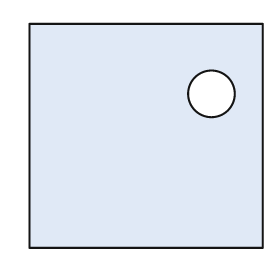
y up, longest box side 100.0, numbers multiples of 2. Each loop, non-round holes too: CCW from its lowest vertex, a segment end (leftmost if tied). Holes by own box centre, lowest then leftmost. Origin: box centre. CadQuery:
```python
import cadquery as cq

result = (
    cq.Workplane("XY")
    .moveTo(-50.0, -48.0)
    .lineTo(50.0, -48.0)
    .lineTo(50.0, 48.0)
    .lineTo(-50.0, 48.0)
    .close()
    .moveTo(28.0, 18.0)
    .circle(10.0)
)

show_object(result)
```